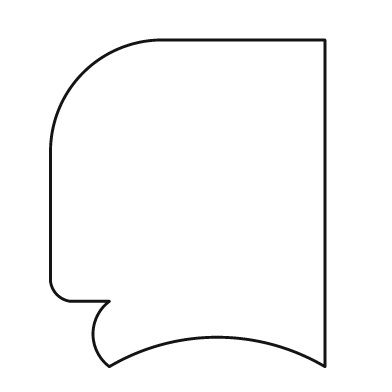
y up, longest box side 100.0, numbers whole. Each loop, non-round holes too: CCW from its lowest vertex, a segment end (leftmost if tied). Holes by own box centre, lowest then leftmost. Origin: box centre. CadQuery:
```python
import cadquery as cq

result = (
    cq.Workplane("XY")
    .moveTo(-24.0, -50.0)
    .threePointArc((9.0, -41.0), (42.0, -50.0))
    .lineTo(42.0, 50.0)
    .lineTo(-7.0, 50.0)
    .threePointArc((-32.0, 40.0), (-42.0, 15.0))
    .lineTo(-42.0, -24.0)
    .threePointArc((-40.0, -28.0), (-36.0, -30.0))
    .lineTo(-24.0, -30.0)
    .threePointArc((-29.0, -40.0), (-24.0, -50.0))
    .close()
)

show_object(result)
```